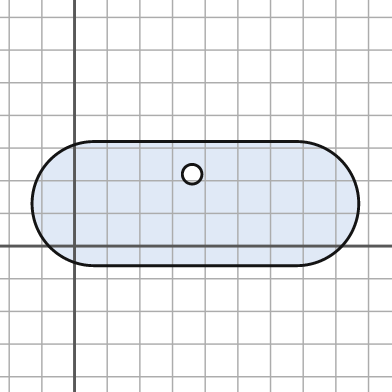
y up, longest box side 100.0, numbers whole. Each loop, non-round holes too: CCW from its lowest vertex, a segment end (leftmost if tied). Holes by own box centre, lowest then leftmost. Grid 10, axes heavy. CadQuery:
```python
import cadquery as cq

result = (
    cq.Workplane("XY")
    .moveTo(6.0, -6.0)
    .lineTo(68.0, -6.0)
    .threePointArc((87.0, 13.0), (68.0, 32.0))
    .lineTo(6.0, 32.0)
    .threePointArc((-13.0, 13.0), (6.0, -6.0))
    .close()
    .moveTo(36.0, 22.0)
    .circle(3.0)
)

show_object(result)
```